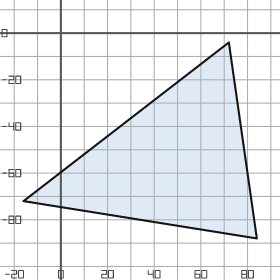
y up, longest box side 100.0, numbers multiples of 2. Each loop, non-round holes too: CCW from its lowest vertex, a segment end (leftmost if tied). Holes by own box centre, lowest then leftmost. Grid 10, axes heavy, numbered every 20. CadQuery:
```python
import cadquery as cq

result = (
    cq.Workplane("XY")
    .moveTo(84.0, -88.0)
    .lineTo(72.0, -4.0)
    .lineTo(-16.0, -72.0)
    .close()
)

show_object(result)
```